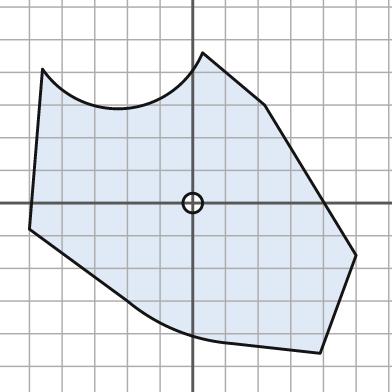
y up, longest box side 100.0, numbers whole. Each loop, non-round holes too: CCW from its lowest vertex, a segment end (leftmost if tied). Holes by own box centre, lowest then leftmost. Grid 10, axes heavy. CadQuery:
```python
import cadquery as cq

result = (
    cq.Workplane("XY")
    .moveTo(39.0, -46.0)
    .lineTo(50.0, -16.0)
    .lineTo(22.0, 30.0)
    .lineTo(3.0, 46.0)
    .threePointArc((-20.0, 29.0), (-46.0, 41.0))
    .lineTo(-50.0, -8.0)
    .lineTo(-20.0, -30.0)
    .threePointArc((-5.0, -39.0), (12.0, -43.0))
    .close()
    .moveTo(0.0, 0.0)
    .circle(3.0)
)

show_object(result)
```